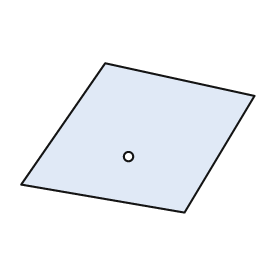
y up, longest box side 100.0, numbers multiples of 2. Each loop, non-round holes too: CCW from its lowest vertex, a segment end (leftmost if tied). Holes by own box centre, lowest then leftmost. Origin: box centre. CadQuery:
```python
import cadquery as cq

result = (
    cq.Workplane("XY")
    .moveTo(20.0, -32.0)
    .lineTo(50.0, 18.0)
    .lineTo(-14.0, 32.0)
    .lineTo(-50.0, -20.0)
    .close()
    .moveTo(-4.0, -8.0)
    .circle(2.0)
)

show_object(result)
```